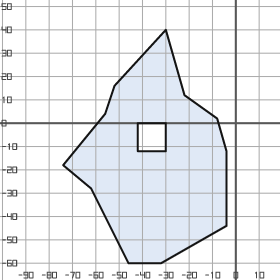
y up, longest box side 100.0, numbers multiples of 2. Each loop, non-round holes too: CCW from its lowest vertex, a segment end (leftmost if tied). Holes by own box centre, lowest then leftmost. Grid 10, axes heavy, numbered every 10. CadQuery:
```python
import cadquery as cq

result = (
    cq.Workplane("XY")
    .moveTo(-46.0, -60.0)
    .lineTo(-32.0, -60.0)
    .lineTo(-4.0, -44.0)
    .lineTo(-4.0, -12.0)
    .lineTo(-8.0, 2.0)
    .lineTo(-22.0, 12.0)
    .lineTo(-30.0, 40.0)
    .lineTo(-52.0, 16.0)
    .lineTo(-56.0, 4.0)
    .lineTo(-74.0, -18.0)
    .lineTo(-62.0, -28.0)
    .close()
    .moveTo(-42.0, -12.0)
    .lineTo(-30.0, -12.0)
    .lineTo(-30.0, 0.0)
    .lineTo(-42.0, 0.0)
    .close()
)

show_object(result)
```